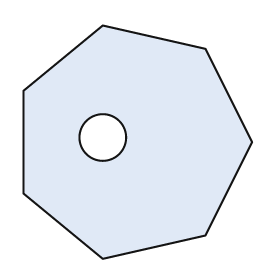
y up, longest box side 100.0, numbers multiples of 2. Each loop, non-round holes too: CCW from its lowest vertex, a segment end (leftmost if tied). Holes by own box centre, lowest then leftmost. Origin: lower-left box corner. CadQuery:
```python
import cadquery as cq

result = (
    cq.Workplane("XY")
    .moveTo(34.0, 0.0)
    .lineTo(78.0, 10.0)
    .lineTo(98.0, 50.0)
    .lineTo(78.0, 90.0)
    .lineTo(34.0, 100.0)
    .lineTo(0.0, 72.0)
    .lineTo(0.0, 28.0)
    .close()
    .moveTo(34.0, 52.0)
    .circle(10.0)
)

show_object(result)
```